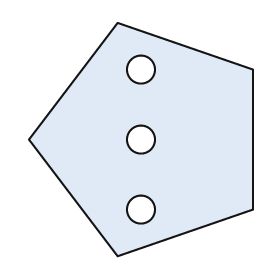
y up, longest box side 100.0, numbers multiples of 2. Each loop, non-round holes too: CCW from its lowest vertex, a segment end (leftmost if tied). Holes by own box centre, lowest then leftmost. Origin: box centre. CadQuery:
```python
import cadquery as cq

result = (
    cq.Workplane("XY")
    .moveTo(-10.0, -50.0)
    .lineTo(48.0, -30.0)
    .lineTo(48.0, 30.0)
    .lineTo(-10.0, 50.0)
    .lineTo(-48.0, 0.0)
    .close()
    .moveTo(0.0, -30.0)
    .circle(6.0)
    .moveTo(0.0, 0.0)
    .circle(6.0)
    .moveTo(0.0, 30.0)
    .circle(6.0)
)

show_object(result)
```